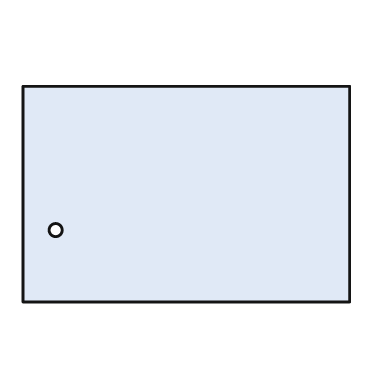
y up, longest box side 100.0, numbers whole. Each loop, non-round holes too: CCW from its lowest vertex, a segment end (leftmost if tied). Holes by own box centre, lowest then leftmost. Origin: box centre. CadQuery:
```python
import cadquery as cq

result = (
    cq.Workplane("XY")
    .moveTo(-50.0, -33.0)
    .lineTo(50.0, -33.0)
    .lineTo(50.0, 33.0)
    .lineTo(-50.0, 33.0)
    .close()
    .moveTo(-40.0, -11.0)
    .circle(2.0)
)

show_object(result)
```